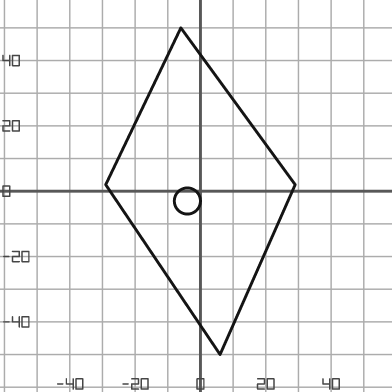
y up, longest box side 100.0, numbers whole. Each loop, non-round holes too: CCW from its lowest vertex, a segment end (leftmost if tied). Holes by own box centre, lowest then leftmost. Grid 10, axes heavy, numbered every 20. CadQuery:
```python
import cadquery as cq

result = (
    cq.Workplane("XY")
    .moveTo(6.0, -50.0)
    .lineTo(29.0, 2.0)
    .lineTo(-6.0, 50.0)
    .lineTo(-29.0, 2.0)
    .close()
    .moveTo(-4.0, -3.0)
    .circle(4.0)
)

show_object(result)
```